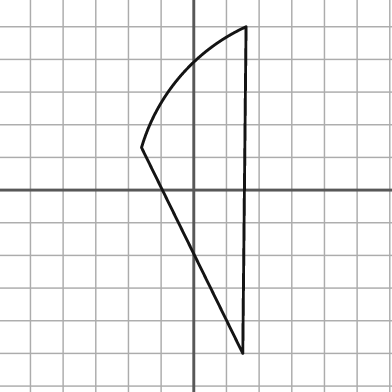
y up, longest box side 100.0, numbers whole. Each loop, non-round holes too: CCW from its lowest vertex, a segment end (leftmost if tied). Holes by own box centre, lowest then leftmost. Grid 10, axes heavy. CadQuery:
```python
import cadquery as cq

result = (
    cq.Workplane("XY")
    .moveTo(15.0, -50.0)
    .lineTo(16.0, 50.0)
    .threePointArc((-4.0, 35.0), (-16.0, 13.0))
    .close()
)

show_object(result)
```